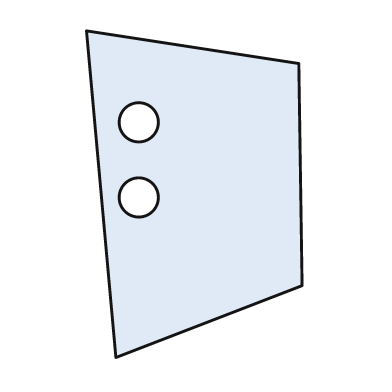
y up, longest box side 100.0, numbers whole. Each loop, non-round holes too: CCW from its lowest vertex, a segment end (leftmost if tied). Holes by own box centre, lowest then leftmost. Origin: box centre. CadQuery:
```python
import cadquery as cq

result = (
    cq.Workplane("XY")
    .moveTo(-24.0, -50.0)
    .lineTo(33.0, -28.0)
    .lineTo(32.0, 40.0)
    .lineTo(-33.0, 50.0)
    .close()
    .moveTo(-17.0, -1.0)
    .circle(6.0)
    .moveTo(-17.0, 22.0)
    .circle(6.0)
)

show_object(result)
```